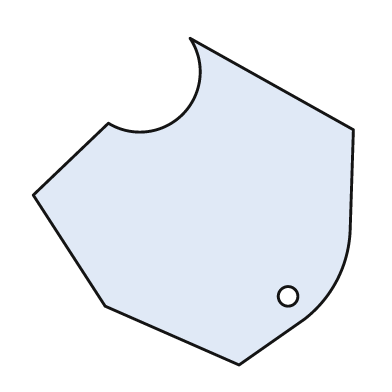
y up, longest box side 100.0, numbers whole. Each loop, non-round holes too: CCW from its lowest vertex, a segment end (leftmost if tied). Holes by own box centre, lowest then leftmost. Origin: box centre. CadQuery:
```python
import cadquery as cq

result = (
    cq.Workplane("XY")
    .moveTo(14.0, -50.0)
    .lineTo(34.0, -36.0)
    .threePointArc((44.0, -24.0), (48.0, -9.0))
    .lineTo(49.0, 22.0)
    .lineTo(-1.0, 50.0)
    .threePointArc((-3.0, 27.0), (-26.0, 24.0))
    .lineTo(-49.0, 2.0)
    .lineTo(-27.0, -32.0)
    .close()
    .moveTo(29.0, -29.0)
    .circle(3.0)
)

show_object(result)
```